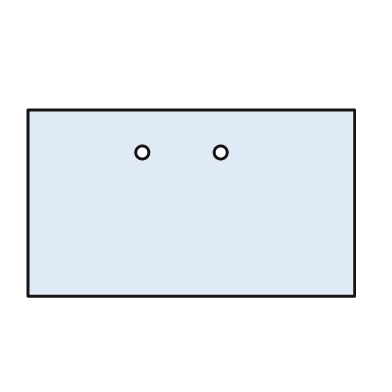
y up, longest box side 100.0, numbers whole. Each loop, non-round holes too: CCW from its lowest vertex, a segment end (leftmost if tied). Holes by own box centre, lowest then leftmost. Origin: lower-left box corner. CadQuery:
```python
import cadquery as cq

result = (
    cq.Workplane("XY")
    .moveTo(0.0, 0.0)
    .lineTo(100.0, 0.0)
    .lineTo(100.0, 57.0)
    .lineTo(0.0, 57.0)
    .close()
    .moveTo(35.0, 44.0)
    .circle(2.0)
    .moveTo(59.0, 44.0)
    .circle(2.0)
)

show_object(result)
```